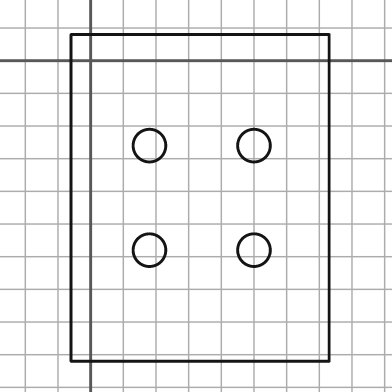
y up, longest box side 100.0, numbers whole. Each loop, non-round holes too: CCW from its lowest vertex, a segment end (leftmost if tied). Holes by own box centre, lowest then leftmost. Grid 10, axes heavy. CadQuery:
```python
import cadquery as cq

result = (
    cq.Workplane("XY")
    .moveTo(-6.0, -92.0)
    .lineTo(73.0, -92.0)
    .lineTo(73.0, 8.0)
    .lineTo(-6.0, 8.0)
    .close()
    .moveTo(18.0, -58.0)
    .circle(5.0)
    .moveTo(50.0, -58.0)
    .circle(5.0)
    .moveTo(18.0, -26.0)
    .circle(5.0)
    .moveTo(50.0, -26.0)
    .circle(5.0)
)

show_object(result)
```